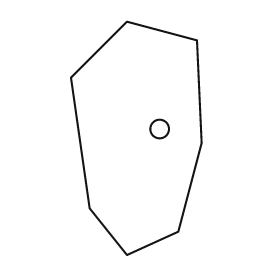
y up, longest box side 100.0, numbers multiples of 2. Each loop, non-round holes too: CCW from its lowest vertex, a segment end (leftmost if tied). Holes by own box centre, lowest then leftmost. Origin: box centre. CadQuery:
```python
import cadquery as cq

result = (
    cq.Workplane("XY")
    .moveTo(-4.0, -50.0)
    .lineTo(18.0, -40.0)
    .lineTo(28.0, -2.0)
    .lineTo(26.0, 42.0)
    .lineTo(-4.0, 50.0)
    .lineTo(-28.0, 26.0)
    .lineTo(-20.0, -30.0)
    .close()
    .moveTo(10.0, 4.0)
    .circle(4.0)
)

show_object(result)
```